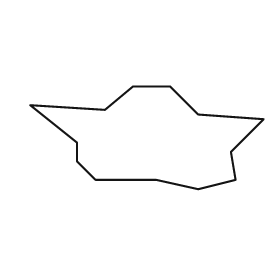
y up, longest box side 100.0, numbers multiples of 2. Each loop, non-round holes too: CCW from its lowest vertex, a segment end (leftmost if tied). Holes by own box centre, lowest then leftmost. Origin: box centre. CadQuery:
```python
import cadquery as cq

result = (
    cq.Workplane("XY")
    .moveTo(22.0, -22.0)
    .lineTo(38.0, -18.0)
    .lineTo(36.0, -6.0)
    .lineTo(50.0, 8.0)
    .lineTo(22.0, 10.0)
    .lineTo(10.0, 22.0)
    .lineTo(-6.0, 22.0)
    .lineTo(-18.0, 12.0)
    .lineTo(-50.0, 14.0)
    .lineTo(-30.0, -2.0)
    .lineTo(-30.0, -10.0)
    .lineTo(-22.0, -18.0)
    .lineTo(4.0, -18.0)
    .close()
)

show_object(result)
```